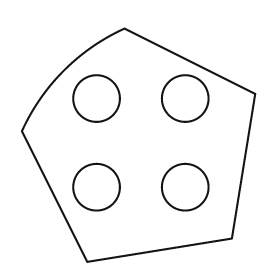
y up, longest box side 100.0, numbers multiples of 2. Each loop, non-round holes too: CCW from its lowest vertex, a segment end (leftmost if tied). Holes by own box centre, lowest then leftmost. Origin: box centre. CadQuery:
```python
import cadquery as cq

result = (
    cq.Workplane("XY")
    .moveTo(-22.0, -50.0)
    .lineTo(40.0, -40.0)
    .lineTo(50.0, 22.0)
    .lineTo(-6.0, 50.0)
    .threePointArc((-32.0, 32.0), (-50.0, 6.0))
    .close()
    .moveTo(-18.0, -18.0)
    .circle(10.0)
    .moveTo(20.0, -18.0)
    .circle(10.0)
    .moveTo(-18.0, 20.0)
    .circle(10.0)
    .moveTo(20.0, 20.0)
    .circle(10.0)
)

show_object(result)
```